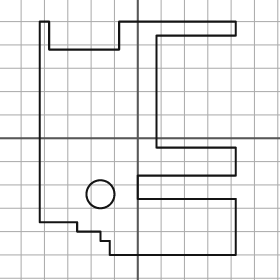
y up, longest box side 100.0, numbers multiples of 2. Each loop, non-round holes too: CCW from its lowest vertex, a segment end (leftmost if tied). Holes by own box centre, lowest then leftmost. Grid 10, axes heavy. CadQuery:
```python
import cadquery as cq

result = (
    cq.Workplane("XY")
    .moveTo(-12.0, -50.0)
    .lineTo(42.0, -50.0)
    .lineTo(42.0, -26.0)
    .lineTo(0.0, -26.0)
    .lineTo(0.0, -16.0)
    .lineTo(42.0, -16.0)
    .lineTo(42.0, -4.0)
    .lineTo(8.0, -4.0)
    .lineTo(8.0, 44.0)
    .lineTo(42.0, 44.0)
    .lineTo(42.0, 50.0)
    .lineTo(-8.0, 50.0)
    .lineTo(-8.0, 38.0)
    .lineTo(-38.0, 38.0)
    .lineTo(-38.0, 50.0)
    .lineTo(-42.0, 50.0)
    .lineTo(-42.0, -36.0)
    .lineTo(-26.0, -36.0)
    .lineTo(-26.0, -40.0)
    .lineTo(-16.0, -40.0)
    .lineTo(-16.0, -44.0)
    .lineTo(-12.0, -44.0)
    .close()
    .moveTo(-16.0, -24.0)
    .circle(6.0)
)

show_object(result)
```